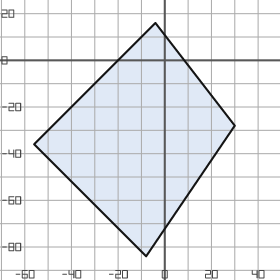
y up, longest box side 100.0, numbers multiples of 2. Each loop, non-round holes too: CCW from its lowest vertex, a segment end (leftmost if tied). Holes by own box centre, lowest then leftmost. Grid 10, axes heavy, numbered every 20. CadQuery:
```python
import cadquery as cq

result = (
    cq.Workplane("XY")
    .moveTo(-8.0, -84.0)
    .lineTo(30.0, -28.0)
    .lineTo(-4.0, 16.0)
    .lineTo(-56.0, -36.0)
    .close()
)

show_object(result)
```